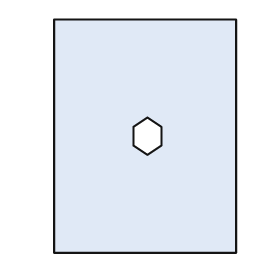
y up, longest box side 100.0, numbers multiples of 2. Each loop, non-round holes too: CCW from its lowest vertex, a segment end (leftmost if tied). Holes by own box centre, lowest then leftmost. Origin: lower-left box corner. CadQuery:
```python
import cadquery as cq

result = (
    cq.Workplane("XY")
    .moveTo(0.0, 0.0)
    .lineTo(78.0, 0.0)
    .lineTo(78.0, 100.0)
    .lineTo(0.0, 100.0)
    .close()
    .moveTo(40.0, 42.0)
    .lineTo(46.0, 46.0)
    .lineTo(46.0, 54.0)
    .lineTo(40.0, 58.0)
    .lineTo(34.0, 54.0)
    .lineTo(34.0, 46.0)
    .close()
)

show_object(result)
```